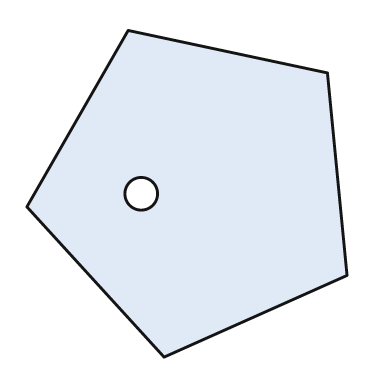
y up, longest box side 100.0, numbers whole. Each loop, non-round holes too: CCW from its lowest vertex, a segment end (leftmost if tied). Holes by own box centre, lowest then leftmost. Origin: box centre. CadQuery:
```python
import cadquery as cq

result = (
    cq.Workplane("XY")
    .moveTo(-7.0, -50.0)
    .lineTo(49.0, -25.0)
    .lineTo(43.0, 37.0)
    .lineTo(-18.0, 50.0)
    .lineTo(-49.0, -4.0)
    .close()
    .moveTo(-14.0, 0.0)
    .circle(5.0)
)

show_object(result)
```